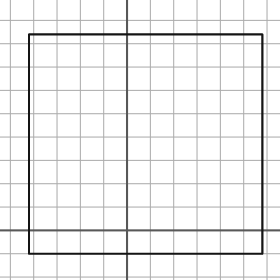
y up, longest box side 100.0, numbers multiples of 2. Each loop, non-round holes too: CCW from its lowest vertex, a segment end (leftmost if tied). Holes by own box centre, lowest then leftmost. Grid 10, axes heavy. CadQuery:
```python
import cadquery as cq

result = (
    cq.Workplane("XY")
    .moveTo(-42.0, -10.0)
    .lineTo(58.0, -10.0)
    .lineTo(58.0, 84.0)
    .lineTo(-42.0, 84.0)
    .close()
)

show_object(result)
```